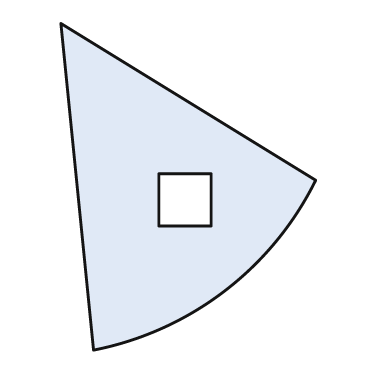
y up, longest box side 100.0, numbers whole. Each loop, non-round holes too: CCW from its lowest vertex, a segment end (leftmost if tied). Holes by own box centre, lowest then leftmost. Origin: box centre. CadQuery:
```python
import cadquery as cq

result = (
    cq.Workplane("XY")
    .moveTo(-29.0, -50.0)
    .threePointArc((11.0, -32.0), (39.0, 2.0))
    .lineTo(-39.0, 50.0)
    .close()
    .moveTo(-9.0, -12.0)
    .lineTo(7.0, -12.0)
    .lineTo(7.0, 4.0)
    .lineTo(-9.0, 4.0)
    .close()
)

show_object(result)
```